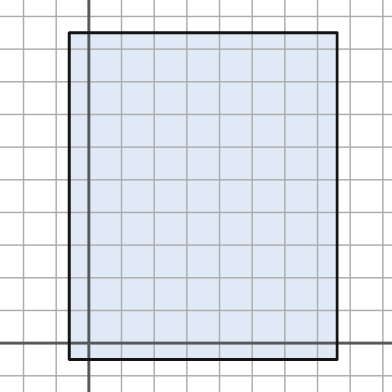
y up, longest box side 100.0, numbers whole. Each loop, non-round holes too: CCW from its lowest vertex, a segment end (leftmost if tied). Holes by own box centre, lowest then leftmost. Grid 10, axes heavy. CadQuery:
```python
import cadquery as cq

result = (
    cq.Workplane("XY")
    .moveTo(-6.0, -5.0)
    .lineTo(76.0, -5.0)
    .lineTo(76.0, 95.0)
    .lineTo(-6.0, 95.0)
    .close()
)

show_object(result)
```